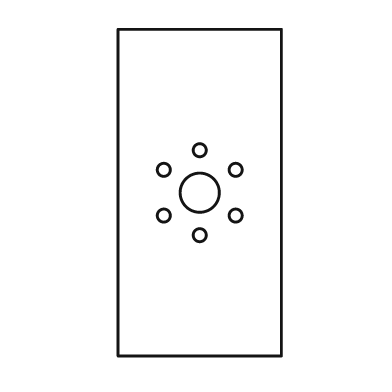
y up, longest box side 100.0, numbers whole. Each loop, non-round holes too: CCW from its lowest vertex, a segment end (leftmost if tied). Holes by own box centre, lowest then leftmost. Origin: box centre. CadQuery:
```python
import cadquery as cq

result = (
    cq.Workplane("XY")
    .moveTo(-25.0, -50.0)
    .lineTo(25.0, -50.0)
    .lineTo(25.0, 50.0)
    .lineTo(-25.0, 50.0)
    .close()
    .moveTo(0.0, -13.0)
    .circle(2.0)
    .moveTo(-11.0, -7.0)
    .circle(2.0)
    .moveTo(11.0, -7.0)
    .circle(2.0)
    .moveTo(0.0, 0.0)
    .circle(6.0)
    .moveTo(-11.0, 7.0)
    .circle(2.0)
    .moveTo(11.0, 7.0)
    .circle(2.0)
    .moveTo(0.0, 13.0)
    .circle(2.0)
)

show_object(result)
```